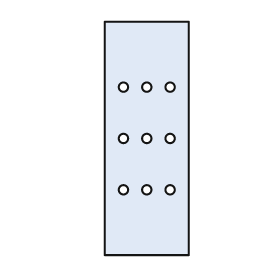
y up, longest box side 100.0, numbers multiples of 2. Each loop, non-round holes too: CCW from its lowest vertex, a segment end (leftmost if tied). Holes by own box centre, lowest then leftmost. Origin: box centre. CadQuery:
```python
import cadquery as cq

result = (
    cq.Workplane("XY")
    .moveTo(-18.0, -50.0)
    .lineTo(18.0, -50.0)
    .lineTo(18.0, 50.0)
    .lineTo(-18.0, 50.0)
    .close()
    .moveTo(-10.0, -22.0)
    .circle(2.0)
    .moveTo(0.0, -22.0)
    .circle(2.0)
    .moveTo(10.0, -22.0)
    .circle(2.0)
    .moveTo(-10.0, 0.0)
    .circle(2.0)
    .moveTo(0.0, 0.0)
    .circle(2.0)
    .moveTo(10.0, 0.0)
    .circle(2.0)
    .moveTo(-10.0, 22.0)
    .circle(2.0)
    .moveTo(0.0, 22.0)
    .circle(2.0)
    .moveTo(10.0, 22.0)
    .circle(2.0)
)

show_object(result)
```